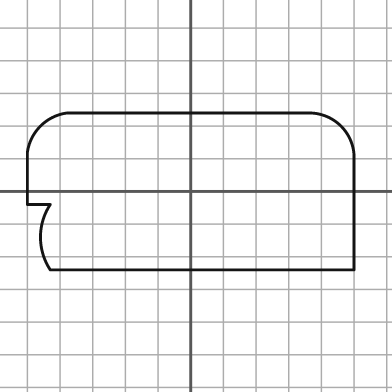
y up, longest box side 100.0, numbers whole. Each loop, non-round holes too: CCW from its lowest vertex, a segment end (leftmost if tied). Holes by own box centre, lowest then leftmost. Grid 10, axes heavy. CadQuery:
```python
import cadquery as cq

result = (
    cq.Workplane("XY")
    .moveTo(-43.0, -24.0)
    .lineTo(50.0, -24.0)
    .lineTo(50.0, 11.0)
    .threePointArc((46.0, 20.0), (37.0, 24.0))
    .lineTo(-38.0, 24.0)
    .threePointArc((-46.0, 20.0), (-50.0, 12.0))
    .lineTo(-50.0, -4.0)
    .lineTo(-43.0, -4.0)
    .threePointArc((-46.0, -14.0), (-43.0, -24.0))
    .close()
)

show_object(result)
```